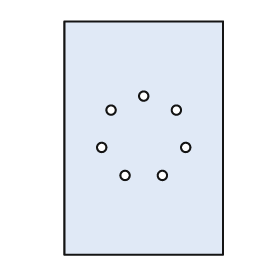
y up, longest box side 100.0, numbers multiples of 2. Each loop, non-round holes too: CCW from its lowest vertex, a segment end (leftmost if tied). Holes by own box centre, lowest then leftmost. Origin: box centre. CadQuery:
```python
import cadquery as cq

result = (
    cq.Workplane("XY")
    .moveTo(-34.0, -50.0)
    .lineTo(34.0, -50.0)
    .lineTo(34.0, 50.0)
    .lineTo(-34.0, 50.0)
    .close()
    .moveTo(-8.0, -16.0)
    .circle(2.0)
    .moveTo(8.0, -16.0)
    .circle(2.0)
    .moveTo(-18.0, -4.0)
    .circle(2.0)
    .moveTo(18.0, -4.0)
    .circle(2.0)
    .moveTo(-14.0, 12.0)
    .circle(2.0)
    .moveTo(14.0, 12.0)
    .circle(2.0)
    .moveTo(0.0, 18.0)
    .circle(2.0)
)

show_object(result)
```